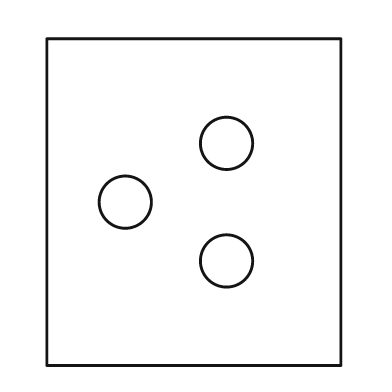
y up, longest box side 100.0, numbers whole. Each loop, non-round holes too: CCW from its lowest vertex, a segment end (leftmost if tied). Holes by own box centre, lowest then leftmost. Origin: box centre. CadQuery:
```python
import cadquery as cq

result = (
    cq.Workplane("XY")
    .moveTo(-45.0, -50.0)
    .lineTo(45.0, -50.0)
    .lineTo(45.0, 50.0)
    .lineTo(-45.0, 50.0)
    .close()
    .moveTo(10.0, -18.0)
    .circle(8.0)
    .moveTo(-21.0, 0.0)
    .circle(8.0)
    .moveTo(10.0, 18.0)
    .circle(8.0)
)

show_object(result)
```